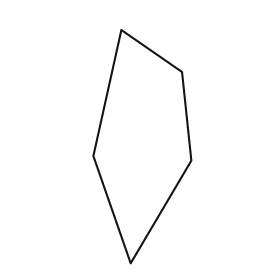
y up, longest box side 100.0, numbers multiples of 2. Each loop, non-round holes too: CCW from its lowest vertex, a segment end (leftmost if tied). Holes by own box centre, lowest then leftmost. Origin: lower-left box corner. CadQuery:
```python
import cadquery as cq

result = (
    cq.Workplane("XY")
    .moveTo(16.0, 0.0)
    .lineTo(42.0, 44.0)
    .lineTo(38.0, 82.0)
    .lineTo(12.0, 100.0)
    .lineTo(0.0, 46.0)
    .close()
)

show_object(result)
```